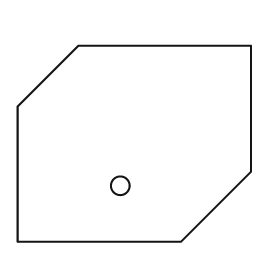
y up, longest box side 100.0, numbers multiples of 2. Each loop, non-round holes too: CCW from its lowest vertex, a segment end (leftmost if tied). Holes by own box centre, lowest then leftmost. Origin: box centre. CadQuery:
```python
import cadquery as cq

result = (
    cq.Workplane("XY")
    .moveTo(-50.0, -42.0)
    .lineTo(20.0, -42.0)
    .lineTo(50.0, -12.0)
    .lineTo(50.0, 42.0)
    .lineTo(-24.0, 42.0)
    .lineTo(-50.0, 16.0)
    .close()
    .moveTo(-6.0, -18.0)
    .circle(4.0)
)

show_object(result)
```